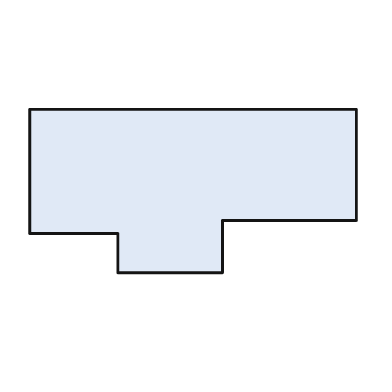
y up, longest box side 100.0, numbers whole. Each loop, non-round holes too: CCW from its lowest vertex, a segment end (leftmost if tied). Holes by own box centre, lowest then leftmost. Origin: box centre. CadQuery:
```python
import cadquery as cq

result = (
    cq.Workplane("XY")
    .moveTo(-23.0, -25.0)
    .lineTo(9.0, -25.0)
    .lineTo(9.0, -9.0)
    .lineTo(50.0, -9.0)
    .lineTo(50.0, 25.0)
    .lineTo(-50.0, 25.0)
    .lineTo(-50.0, -13.0)
    .lineTo(-23.0, -13.0)
    .close()
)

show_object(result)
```